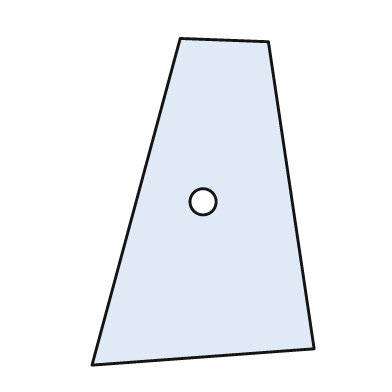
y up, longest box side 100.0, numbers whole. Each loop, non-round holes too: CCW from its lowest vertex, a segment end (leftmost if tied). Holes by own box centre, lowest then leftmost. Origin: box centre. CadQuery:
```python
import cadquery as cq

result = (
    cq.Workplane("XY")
    .moveTo(-34.0, -50.0)
    .lineTo(34.0, -45.0)
    .lineTo(20.0, 49.0)
    .lineTo(-7.0, 50.0)
    .close()
    .moveTo(0.0, 0.0)
    .circle(4.0)
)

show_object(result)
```